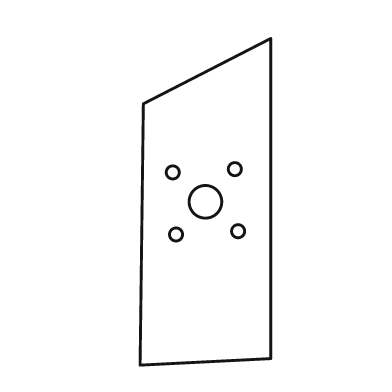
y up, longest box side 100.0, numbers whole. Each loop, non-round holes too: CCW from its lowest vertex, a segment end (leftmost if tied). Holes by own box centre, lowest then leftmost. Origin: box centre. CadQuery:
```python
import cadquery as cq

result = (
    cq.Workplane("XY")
    .moveTo(-20.0, -50.0)
    .lineTo(20.0, -48.0)
    .lineTo(20.0, 50.0)
    .lineTo(-19.0, 30.0)
    .close()
    .moveTo(-9.0, -10.0)
    .circle(2.0)
    .moveTo(10.0, -9.0)
    .circle(2.0)
    .moveTo(0.0, 0.0)
    .circle(5.0)
    .moveTo(-10.0, 9.0)
    .circle(2.0)
    .moveTo(9.0, 10.0)
    .circle(2.0)
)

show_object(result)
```